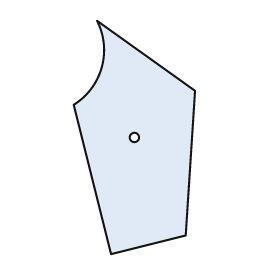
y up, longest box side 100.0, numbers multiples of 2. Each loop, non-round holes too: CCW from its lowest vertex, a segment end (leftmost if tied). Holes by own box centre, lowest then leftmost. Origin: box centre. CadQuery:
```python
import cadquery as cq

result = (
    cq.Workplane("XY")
    .moveTo(-10.0, -50.0)
    .lineTo(22.0, -42.0)
    .lineTo(26.0, 20.0)
    .lineTo(-16.0, 50.0)
    .threePointArc((-14.0, 30.0), (-26.0, 14.0))
    .close()
    .moveTo(0.0, 0.0)
    .circle(2.0)
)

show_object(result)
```